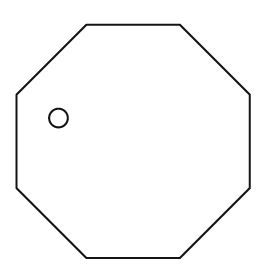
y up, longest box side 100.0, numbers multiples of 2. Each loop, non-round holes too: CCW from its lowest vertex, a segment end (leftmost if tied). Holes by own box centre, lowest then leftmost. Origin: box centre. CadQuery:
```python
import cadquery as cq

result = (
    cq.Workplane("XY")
    .moveTo(-20.0, -50.0)
    .lineTo(20.0, -50.0)
    .lineTo(50.0, -20.0)
    .lineTo(50.0, 20.0)
    .lineTo(20.0, 50.0)
    .lineTo(-20.0, 50.0)
    .lineTo(-50.0, 20.0)
    .lineTo(-50.0, -20.0)
    .close()
    .moveTo(-32.0, 10.0)
    .circle(4.0)
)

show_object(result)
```